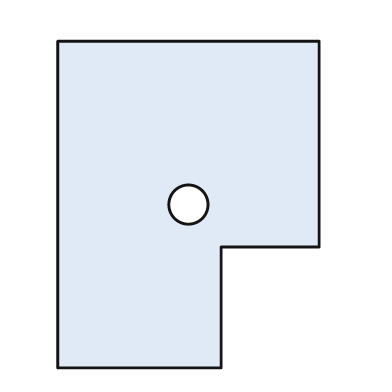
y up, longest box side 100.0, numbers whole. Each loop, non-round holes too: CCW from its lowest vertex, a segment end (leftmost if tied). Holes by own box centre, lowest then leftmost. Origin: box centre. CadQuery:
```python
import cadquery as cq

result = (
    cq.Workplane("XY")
    .moveTo(-40.0, -50.0)
    .lineTo(10.0, -50.0)
    .lineTo(10.0, -13.0)
    .lineTo(40.0, -13.0)
    .lineTo(40.0, 50.0)
    .lineTo(-40.0, 50.0)
    .close()
    .moveTo(0.0, 0.0)
    .circle(6.0)
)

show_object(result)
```